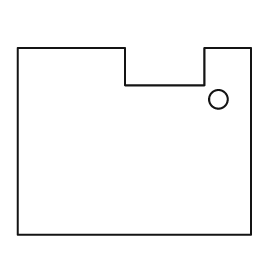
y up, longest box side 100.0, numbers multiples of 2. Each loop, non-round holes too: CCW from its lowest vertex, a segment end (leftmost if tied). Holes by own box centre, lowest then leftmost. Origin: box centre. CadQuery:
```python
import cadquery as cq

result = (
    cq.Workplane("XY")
    .moveTo(-50.0, -40.0)
    .lineTo(50.0, -40.0)
    .lineTo(50.0, 40.0)
    .lineTo(30.0, 40.0)
    .lineTo(30.0, 24.0)
    .lineTo(-4.0, 24.0)
    .lineTo(-4.0, 40.0)
    .lineTo(-50.0, 40.0)
    .close()
    .moveTo(36.0, 18.0)
    .circle(4.0)
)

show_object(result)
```